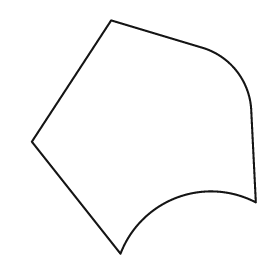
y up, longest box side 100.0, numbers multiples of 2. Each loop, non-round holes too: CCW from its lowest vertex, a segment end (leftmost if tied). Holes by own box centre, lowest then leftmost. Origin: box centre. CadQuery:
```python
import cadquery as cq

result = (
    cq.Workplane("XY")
    .moveTo(-10.0, -50.0)
    .threePointArc((14.0, -26.0), (48.0, -28.0))
    .lineTo(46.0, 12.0)
    .threePointArc((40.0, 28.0), (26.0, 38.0))
    .lineTo(-14.0, 50.0)
    .lineTo(-48.0, -2.0)
    .close()
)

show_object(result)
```